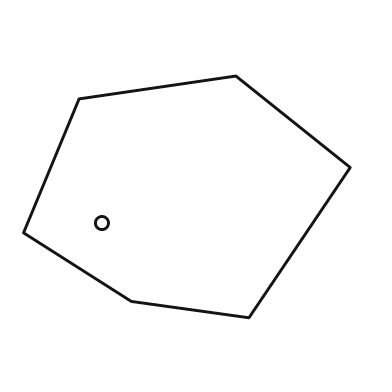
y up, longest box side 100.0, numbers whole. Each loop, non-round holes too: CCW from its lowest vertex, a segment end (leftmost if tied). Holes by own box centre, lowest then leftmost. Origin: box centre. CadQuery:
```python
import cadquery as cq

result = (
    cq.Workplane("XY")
    .moveTo(19.0, -37.0)
    .lineTo(50.0, 9.0)
    .lineTo(15.0, 37.0)
    .lineTo(-33.0, 30.0)
    .lineTo(-50.0, -11.0)
    .lineTo(-17.0, -32.0)
    .close()
    .moveTo(-26.0, -8.0)
    .circle(2.0)
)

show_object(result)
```